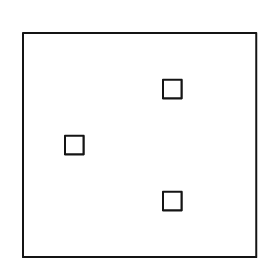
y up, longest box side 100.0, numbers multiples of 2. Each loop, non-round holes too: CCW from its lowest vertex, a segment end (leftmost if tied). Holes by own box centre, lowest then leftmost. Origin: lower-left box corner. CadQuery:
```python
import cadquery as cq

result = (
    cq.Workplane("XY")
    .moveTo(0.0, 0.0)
    .lineTo(100.0, 0.0)
    .lineTo(100.0, 96.0)
    .lineTo(0.0, 96.0)
    .close()
    .moveTo(60.0, 20.0)
    .lineTo(68.0, 20.0)
    .lineTo(68.0, 28.0)
    .lineTo(60.0, 28.0)
    .close()
    .moveTo(18.0, 44.0)
    .lineTo(26.0, 44.0)
    .lineTo(26.0, 52.0)
    .lineTo(18.0, 52.0)
    .close()
    .moveTo(60.0, 68.0)
    .lineTo(68.0, 68.0)
    .lineTo(68.0, 76.0)
    .lineTo(60.0, 76.0)
    .close()
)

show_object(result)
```